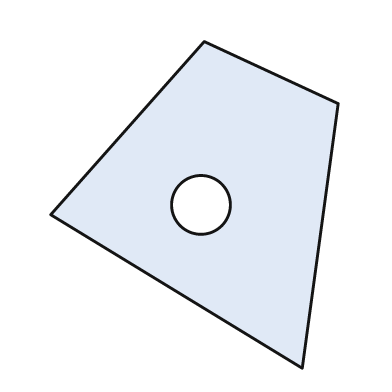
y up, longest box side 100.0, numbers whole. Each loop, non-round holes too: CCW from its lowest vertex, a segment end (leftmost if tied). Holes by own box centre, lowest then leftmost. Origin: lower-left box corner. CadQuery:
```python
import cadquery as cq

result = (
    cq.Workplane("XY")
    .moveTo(77.0, 0.0)
    .lineTo(88.0, 81.0)
    .lineTo(47.0, 100.0)
    .lineTo(0.0, 47.0)
    .close()
    .moveTo(46.0, 50.0)
    .circle(9.0)
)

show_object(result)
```